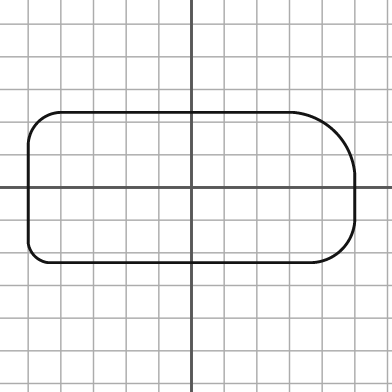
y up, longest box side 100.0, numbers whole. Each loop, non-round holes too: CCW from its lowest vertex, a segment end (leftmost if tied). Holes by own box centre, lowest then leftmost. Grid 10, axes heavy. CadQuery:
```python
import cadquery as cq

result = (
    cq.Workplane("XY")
    .moveTo(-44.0, -23.0)
    .lineTo(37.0, -23.0)
    .threePointArc((46.0, -19.0), (50.0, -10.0))
    .lineTo(50.0, 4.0)
    .threePointArc((44.0, 17.0), (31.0, 23.0))
    .lineTo(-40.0, 23.0)
    .threePointArc((-47.0, 20.0), (-50.0, 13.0))
    .lineTo(-50.0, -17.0)
    .threePointArc((-48.0, -21.0), (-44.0, -23.0))
    .close()
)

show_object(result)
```